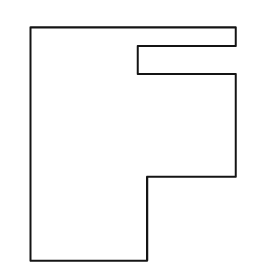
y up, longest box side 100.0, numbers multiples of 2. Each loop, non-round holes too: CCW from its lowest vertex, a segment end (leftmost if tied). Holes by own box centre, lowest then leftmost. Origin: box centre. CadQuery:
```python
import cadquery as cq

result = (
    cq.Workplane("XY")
    .moveTo(-44.0, -50.0)
    .lineTo(6.0, -50.0)
    .lineTo(6.0, -14.0)
    .lineTo(44.0, -14.0)
    .lineTo(44.0, 30.0)
    .lineTo(2.0, 30.0)
    .lineTo(2.0, 42.0)
    .lineTo(44.0, 42.0)
    .lineTo(44.0, 50.0)
    .lineTo(-44.0, 50.0)
    .close()
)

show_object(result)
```